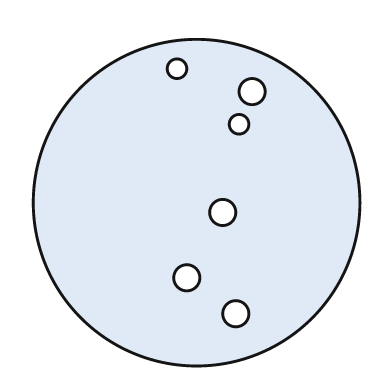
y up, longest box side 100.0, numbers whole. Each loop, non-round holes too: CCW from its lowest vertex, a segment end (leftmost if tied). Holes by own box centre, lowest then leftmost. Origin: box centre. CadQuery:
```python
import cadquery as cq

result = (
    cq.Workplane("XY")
    .moveTo(0.0, 0.0)
    .circle(50.0)
    .moveTo(12.0, -34.0)
    .circle(4.0)
    .moveTo(-3.0, -23.0)
    .circle(4.0)
    .moveTo(8.0, -3.0)
    .circle(4.0)
    .moveTo(13.0, 24.0)
    .circle(3.0)
    .moveTo(17.0, 34.0)
    .circle(4.0)
    .moveTo(-6.0, 41.0)
    .circle(3.0)
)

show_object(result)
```